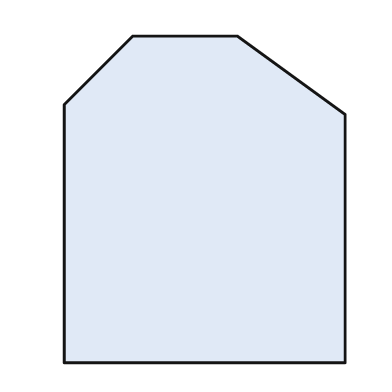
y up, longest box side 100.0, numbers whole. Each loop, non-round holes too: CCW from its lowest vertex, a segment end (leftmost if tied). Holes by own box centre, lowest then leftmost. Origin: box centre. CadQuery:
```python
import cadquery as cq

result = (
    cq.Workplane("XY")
    .moveTo(-43.0, -50.0)
    .lineTo(43.0, -50.0)
    .lineTo(43.0, 26.0)
    .lineTo(10.0, 50.0)
    .lineTo(-22.0, 50.0)
    .lineTo(-43.0, 29.0)
    .close()
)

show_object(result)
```